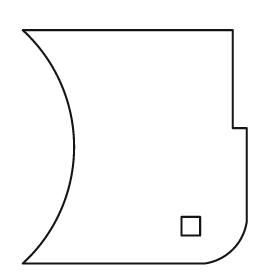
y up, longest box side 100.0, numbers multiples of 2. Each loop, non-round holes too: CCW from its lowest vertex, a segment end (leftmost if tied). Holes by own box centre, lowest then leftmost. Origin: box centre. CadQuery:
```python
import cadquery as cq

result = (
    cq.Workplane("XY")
    .moveTo(-48.0, -50.0)
    .lineTo(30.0, -50.0)
    .threePointArc((42.0, -44.0), (48.0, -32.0))
    .lineTo(48.0, 8.0)
    .lineTo(42.0, 8.0)
    .lineTo(42.0, 50.0)
    .lineTo(-48.0, 50.0)
    .threePointArc((-26.0, 0.0), (-48.0, -50.0))
    .close()
    .moveTo(20.0, -38.0)
    .lineTo(28.0, -38.0)
    .lineTo(28.0, -30.0)
    .lineTo(20.0, -30.0)
    .close()
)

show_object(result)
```